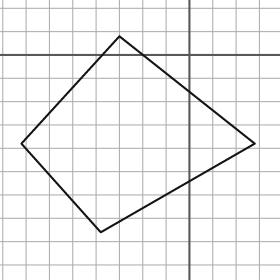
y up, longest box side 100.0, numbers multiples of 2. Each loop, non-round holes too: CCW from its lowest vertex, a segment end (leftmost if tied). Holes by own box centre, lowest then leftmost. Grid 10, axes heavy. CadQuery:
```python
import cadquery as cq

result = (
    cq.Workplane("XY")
    .moveTo(-38.0, -76.0)
    .lineTo(28.0, -38.0)
    .lineTo(-30.0, 8.0)
    .lineTo(-72.0, -38.0)
    .close()
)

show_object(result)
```